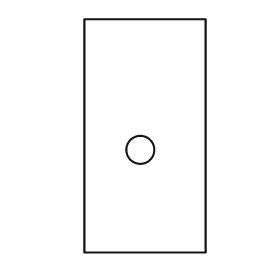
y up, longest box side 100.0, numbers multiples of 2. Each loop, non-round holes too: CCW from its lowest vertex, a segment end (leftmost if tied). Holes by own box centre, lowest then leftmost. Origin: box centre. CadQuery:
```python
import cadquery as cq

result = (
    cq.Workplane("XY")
    .moveTo(-26.0, -50.0)
    .lineTo(26.0, -50.0)
    .lineTo(26.0, 50.0)
    .lineTo(-26.0, 50.0)
    .close()
    .moveTo(-2.0, -6.0)
    .circle(6.0)
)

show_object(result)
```